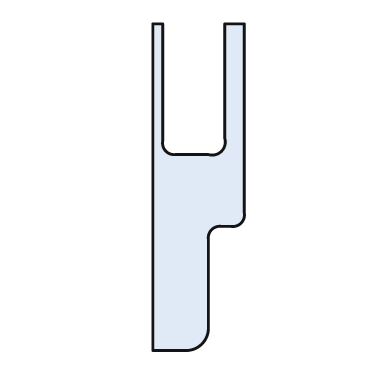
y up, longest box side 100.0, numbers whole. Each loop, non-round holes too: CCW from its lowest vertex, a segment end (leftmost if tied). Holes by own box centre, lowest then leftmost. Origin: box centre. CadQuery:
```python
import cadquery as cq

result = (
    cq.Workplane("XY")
    .moveTo(-14.0, -50.0)
    .lineTo(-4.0, -50.0)
    .threePointArc((1.0, -48.0), (3.0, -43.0))
    .lineTo(3.0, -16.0)
    .threePointArc((4.0, -13.0), (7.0, -12.0))
    .lineTo(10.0, -12.0)
    .threePointArc((13.0, -11.0), (14.0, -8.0))
    .lineTo(14.0, 50.0)
    .lineTo(8.0, 50.0)
    .lineTo(8.0, 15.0)
    .threePointArc((7.0, 11.0), (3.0, 10.0))
    .lineTo(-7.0, 10.0)
    .threePointArc((-10.0, 11.0), (-11.0, 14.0))
    .lineTo(-11.0, 50.0)
    .lineTo(-14.0, 50.0)
    .close()
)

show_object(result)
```